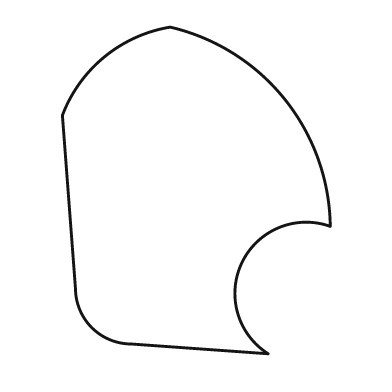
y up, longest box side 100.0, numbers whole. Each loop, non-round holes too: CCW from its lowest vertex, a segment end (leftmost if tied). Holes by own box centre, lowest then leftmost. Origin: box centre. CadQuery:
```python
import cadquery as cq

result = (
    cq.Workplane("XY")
    .moveTo(22.0, -50.0)
    .threePointArc((14.0, -22.0), (41.0, -11.0))
    .threePointArc((27.0, 28.0), (-8.0, 50.0))
    .threePointArc((-28.0, 41.0), (-41.0, 23.0))
    .lineTo(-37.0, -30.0)
    .threePointArc((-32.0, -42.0), (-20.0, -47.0))
    .close()
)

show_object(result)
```